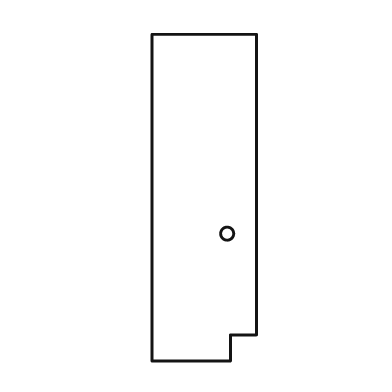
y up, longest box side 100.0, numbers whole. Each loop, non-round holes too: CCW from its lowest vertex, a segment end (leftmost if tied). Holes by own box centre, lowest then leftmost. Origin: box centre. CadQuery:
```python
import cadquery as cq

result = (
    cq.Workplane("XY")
    .moveTo(-16.0, -50.0)
    .lineTo(8.0, -50.0)
    .lineTo(8.0, -42.0)
    .lineTo(16.0, -42.0)
    .lineTo(16.0, 50.0)
    .lineTo(-16.0, 50.0)
    .close()
    .moveTo(7.0, -11.0)
    .circle(2.0)
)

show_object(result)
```